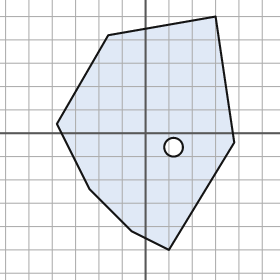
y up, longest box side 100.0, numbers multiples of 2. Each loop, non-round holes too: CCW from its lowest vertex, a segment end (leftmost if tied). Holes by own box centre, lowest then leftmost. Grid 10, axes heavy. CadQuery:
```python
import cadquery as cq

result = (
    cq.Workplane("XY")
    .moveTo(10.0, -50.0)
    .lineTo(38.0, -4.0)
    .lineTo(30.0, 50.0)
    .lineTo(-16.0, 42.0)
    .lineTo(-38.0, 4.0)
    .lineTo(-24.0, -24.0)
    .lineTo(-6.0, -42.0)
    .close()
    .moveTo(12.0, -6.0)
    .circle(4.0)
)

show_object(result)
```